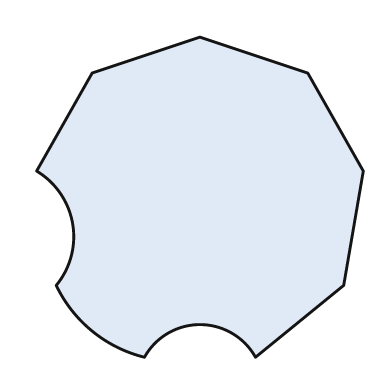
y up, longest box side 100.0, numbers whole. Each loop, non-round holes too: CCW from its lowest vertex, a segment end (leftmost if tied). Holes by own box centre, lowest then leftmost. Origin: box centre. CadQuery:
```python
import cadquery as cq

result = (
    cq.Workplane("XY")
    .moveTo(-17.0, -49.0)
    .threePointArc((0.0, -39.0), (17.0, -49.0))
    .lineTo(44.0, -27.0)
    .lineTo(50.0, 8.0)
    .lineTo(33.0, 38.0)
    .lineTo(0.0, 49.0)
    .lineTo(-33.0, 38.0)
    .lineTo(-50.0, 8.0)
    .threePointArc((-39.0, -8.0), (-44.0, -27.0))
    .threePointArc((-33.0, -41.0), (-17.0, -49.0))
    .close()
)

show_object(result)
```